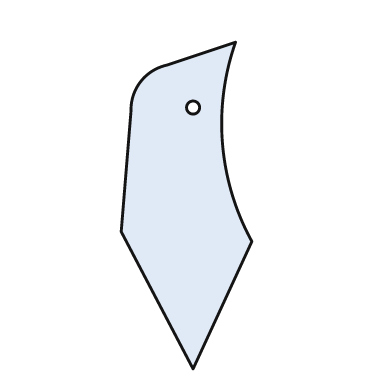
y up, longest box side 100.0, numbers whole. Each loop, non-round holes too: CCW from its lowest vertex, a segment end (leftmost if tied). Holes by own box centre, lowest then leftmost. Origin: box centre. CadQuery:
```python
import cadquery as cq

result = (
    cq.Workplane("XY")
    .moveTo(2.0, -50.0)
    .lineTo(20.0, -11.0)
    .threePointArc((11.0, 19.0), (15.0, 50.0))
    .lineTo(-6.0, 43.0)
    .threePointArc((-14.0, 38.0), (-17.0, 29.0))
    .lineTo(-20.0, -8.0)
    .close()
    .moveTo(2.0, 30.0)
    .circle(2.0)
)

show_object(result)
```